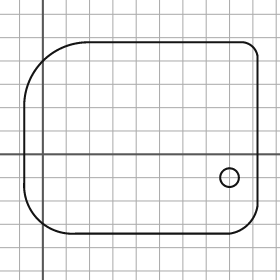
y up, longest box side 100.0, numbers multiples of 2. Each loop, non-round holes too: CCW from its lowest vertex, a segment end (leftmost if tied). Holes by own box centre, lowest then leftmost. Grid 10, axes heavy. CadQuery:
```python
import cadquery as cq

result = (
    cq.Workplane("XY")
    .moveTo(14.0, -34.0)
    .lineTo(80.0, -34.0)
    .threePointArc((88.0, -30.0), (92.0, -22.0))
    .lineTo(92.0, 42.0)
    .threePointArc((90.0, 46.0), (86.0, 48.0))
    .lineTo(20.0, 48.0)
    .threePointArc((0.0, 40.0), (-8.0, 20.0))
    .lineTo(-8.0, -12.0)
    .threePointArc((-2.0, -28.0), (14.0, -34.0))
    .close()
    .moveTo(80.0, -10.0)
    .circle(4.0)
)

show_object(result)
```